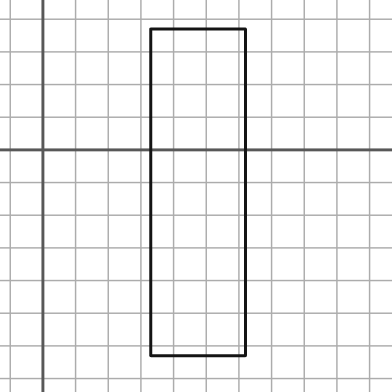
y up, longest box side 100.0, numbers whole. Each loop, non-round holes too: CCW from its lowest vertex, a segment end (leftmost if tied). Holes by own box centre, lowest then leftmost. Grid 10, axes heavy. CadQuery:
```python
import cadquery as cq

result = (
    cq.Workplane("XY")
    .moveTo(33.0, -63.0)
    .lineTo(62.0, -63.0)
    .lineTo(62.0, 37.0)
    .lineTo(33.0, 37.0)
    .close()
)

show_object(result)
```